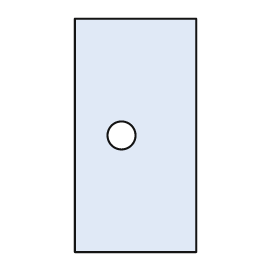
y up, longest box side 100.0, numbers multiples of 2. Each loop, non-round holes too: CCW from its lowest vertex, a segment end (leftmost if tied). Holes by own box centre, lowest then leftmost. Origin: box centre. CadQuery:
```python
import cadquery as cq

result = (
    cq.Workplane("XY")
    .moveTo(-26.0, -50.0)
    .lineTo(26.0, -50.0)
    .lineTo(26.0, 50.0)
    .lineTo(-26.0, 50.0)
    .close()
    .moveTo(-6.0, 0.0)
    .circle(6.0)
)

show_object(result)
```